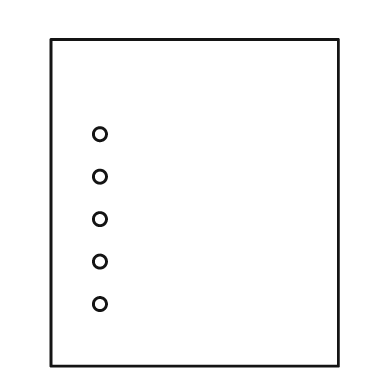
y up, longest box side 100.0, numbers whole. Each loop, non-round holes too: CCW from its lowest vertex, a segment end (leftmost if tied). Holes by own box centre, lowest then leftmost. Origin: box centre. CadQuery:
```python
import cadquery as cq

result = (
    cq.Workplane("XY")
    .moveTo(-44.0, -50.0)
    .lineTo(44.0, -50.0)
    .lineTo(44.0, 50.0)
    .lineTo(-44.0, 50.0)
    .close()
    .moveTo(-29.0, -31.0)
    .circle(2.0)
    .moveTo(-29.0, -18.0)
    .circle(2.0)
    .moveTo(-29.0, -5.0)
    .circle(2.0)
    .moveTo(-29.0, 8.0)
    .circle(2.0)
    .moveTo(-29.0, 21.0)
    .circle(2.0)
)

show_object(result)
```